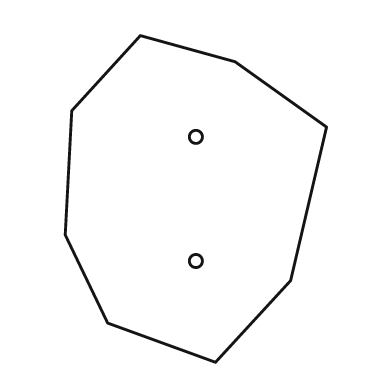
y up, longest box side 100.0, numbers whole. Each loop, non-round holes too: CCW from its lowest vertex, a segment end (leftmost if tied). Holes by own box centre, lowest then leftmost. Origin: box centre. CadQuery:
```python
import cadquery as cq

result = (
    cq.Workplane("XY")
    .moveTo(6.0, -50.0)
    .lineTo(29.0, -25.0)
    .lineTo(40.0, 22.0)
    .lineTo(12.0, 42.0)
    .lineTo(-17.0, 50.0)
    .lineTo(-38.0, 27.0)
    .lineTo(-40.0, -11.0)
    .lineTo(-27.0, -38.0)
    .close()
    .moveTo(0.0, -19.0)
    .circle(2.0)
    .moveTo(0.0, 19.0)
    .circle(2.0)
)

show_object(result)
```